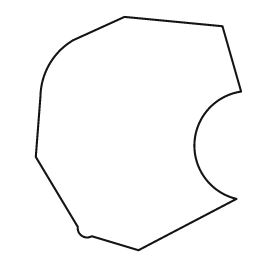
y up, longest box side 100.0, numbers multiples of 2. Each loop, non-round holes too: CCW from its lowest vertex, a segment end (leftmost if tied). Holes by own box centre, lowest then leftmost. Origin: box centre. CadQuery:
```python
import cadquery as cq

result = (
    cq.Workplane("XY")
    .moveTo(0.0, -50.0)
    .lineTo(42.0, -28.0)
    .threePointArc((24.0, -4.0), (44.0, 18.0))
    .lineTo(36.0, 46.0)
    .lineTo(-6.0, 50.0)
    .lineTo(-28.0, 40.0)
    .threePointArc((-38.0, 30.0), (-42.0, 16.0))
    .lineTo(-44.0, -10.0)
    .lineTo(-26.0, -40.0)
    .threePointArc((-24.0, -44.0), (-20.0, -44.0))
    .close()
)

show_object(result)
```